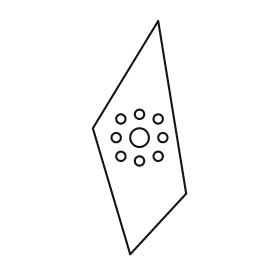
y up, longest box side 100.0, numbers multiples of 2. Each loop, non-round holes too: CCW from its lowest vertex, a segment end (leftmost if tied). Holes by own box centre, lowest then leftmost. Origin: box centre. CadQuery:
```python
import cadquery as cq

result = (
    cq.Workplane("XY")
    .moveTo(-4.0, -50.0)
    .lineTo(20.0, -24.0)
    .lineTo(8.0, 50.0)
    .lineTo(-20.0, 4.0)
    .close()
    .moveTo(0.0, -10.0)
    .circle(2.0)
    .moveTo(-8.0, -8.0)
    .circle(2.0)
    .moveTo(8.0, -8.0)
    .circle(2.0)
    .moveTo(-10.0, 0.0)
    .circle(2.0)
    .moveTo(0.0, 0.0)
    .circle(4.0)
    .moveTo(10.0, 0.0)
    .circle(2.0)
    .moveTo(-8.0, 8.0)
    .circle(2.0)
    .moveTo(8.0, 8.0)
    .circle(2.0)
    .moveTo(0.0, 10.0)
    .circle(2.0)
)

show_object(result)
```